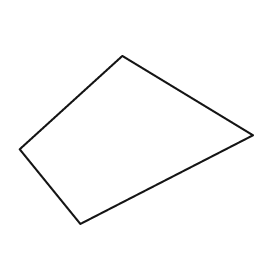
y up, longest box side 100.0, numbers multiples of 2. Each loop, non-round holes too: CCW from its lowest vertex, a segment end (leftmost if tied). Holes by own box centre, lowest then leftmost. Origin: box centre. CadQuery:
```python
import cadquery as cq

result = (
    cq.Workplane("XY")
    .moveTo(-24.0, -36.0)
    .lineTo(50.0, 2.0)
    .lineTo(-6.0, 36.0)
    .lineTo(-50.0, -4.0)
    .close()
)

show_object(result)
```